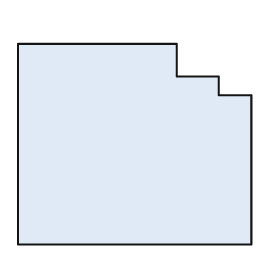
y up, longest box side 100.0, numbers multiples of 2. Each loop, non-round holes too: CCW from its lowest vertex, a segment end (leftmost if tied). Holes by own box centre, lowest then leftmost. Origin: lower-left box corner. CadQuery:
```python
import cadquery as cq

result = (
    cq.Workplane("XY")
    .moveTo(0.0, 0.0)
    .lineTo(100.0, 0.0)
    .lineTo(100.0, 64.0)
    .lineTo(86.0, 64.0)
    .lineTo(86.0, 72.0)
    .lineTo(68.0, 72.0)
    .lineTo(68.0, 86.0)
    .lineTo(0.0, 86.0)
    .close()
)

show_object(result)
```